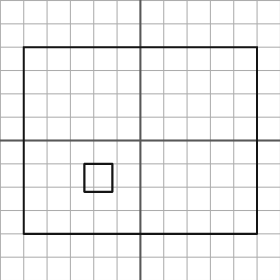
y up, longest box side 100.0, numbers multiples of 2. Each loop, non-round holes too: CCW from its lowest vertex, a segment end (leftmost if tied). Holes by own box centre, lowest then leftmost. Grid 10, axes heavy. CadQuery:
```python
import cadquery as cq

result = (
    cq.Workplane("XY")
    .moveTo(-50.0, -40.0)
    .lineTo(50.0, -40.0)
    .lineTo(50.0, 40.0)
    .lineTo(-50.0, 40.0)
    .close()
    .moveTo(-24.0, -22.0)
    .lineTo(-12.0, -22.0)
    .lineTo(-12.0, -10.0)
    .lineTo(-24.0, -10.0)
    .close()
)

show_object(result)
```